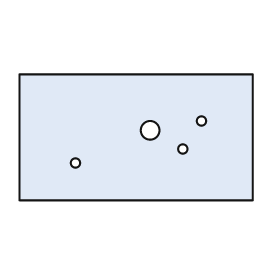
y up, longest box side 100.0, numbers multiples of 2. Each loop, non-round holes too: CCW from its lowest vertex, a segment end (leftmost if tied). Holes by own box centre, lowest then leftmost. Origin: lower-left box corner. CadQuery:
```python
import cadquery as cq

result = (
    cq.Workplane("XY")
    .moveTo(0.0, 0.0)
    .lineTo(100.0, 0.0)
    .lineTo(100.0, 54.0)
    .lineTo(0.0, 54.0)
    .close()
    .moveTo(24.0, 16.0)
    .circle(2.0)
    .moveTo(70.0, 22.0)
    .circle(2.0)
    .moveTo(56.0, 30.0)
    .circle(4.0)
    .moveTo(78.0, 34.0)
    .circle(2.0)
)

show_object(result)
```